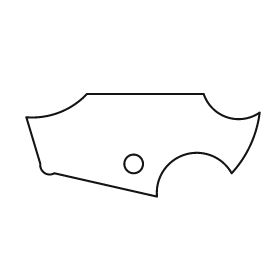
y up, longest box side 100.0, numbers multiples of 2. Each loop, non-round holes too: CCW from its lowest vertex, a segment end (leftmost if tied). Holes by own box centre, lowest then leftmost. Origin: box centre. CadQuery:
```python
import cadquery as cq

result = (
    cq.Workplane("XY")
    .moveTo(6.0, -22.0)
    .threePointArc((18.0, -4.0), (38.0, -12.0))
    .threePointArc((46.0, 0.0), (50.0, 14.0))
    .threePointArc((36.0, 12.0), (26.0, 22.0))
    .lineTo(-24.0, 22.0)
    .threePointArc((-36.0, 14.0), (-50.0, 12.0))
    .lineTo(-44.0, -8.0)
    .threePointArc((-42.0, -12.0), (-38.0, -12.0))
    .close()
    .moveTo(-4.0, -8.0)
    .circle(4.0)
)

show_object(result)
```